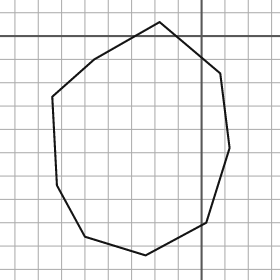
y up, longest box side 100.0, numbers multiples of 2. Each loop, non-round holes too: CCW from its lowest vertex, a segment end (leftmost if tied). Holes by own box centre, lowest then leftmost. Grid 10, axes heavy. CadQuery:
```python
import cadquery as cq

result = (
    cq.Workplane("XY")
    .moveTo(-24.0, -94.0)
    .lineTo(2.0, -80.0)
    .lineTo(12.0, -48.0)
    .lineTo(8.0, -16.0)
    .lineTo(-18.0, 6.0)
    .lineTo(-46.0, -10.0)
    .lineTo(-64.0, -26.0)
    .lineTo(-62.0, -64.0)
    .lineTo(-50.0, -86.0)
    .close()
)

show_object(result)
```